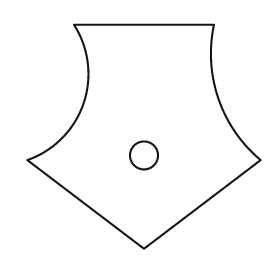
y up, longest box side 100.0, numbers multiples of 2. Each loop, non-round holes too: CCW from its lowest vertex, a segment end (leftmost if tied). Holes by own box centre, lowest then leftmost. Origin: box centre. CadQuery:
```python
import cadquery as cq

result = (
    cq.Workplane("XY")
    .moveTo(0.0, -48.0)
    .lineTo(50.0, -10.0)
    .threePointArc((32.0, 16.0), (30.0, 48.0))
    .lineTo(-30.0, 48.0)
    .threePointArc((-26.0, 14.0), (-50.0, -10.0))
    .close()
    .moveTo(0.0, -8.0)
    .circle(6.0)
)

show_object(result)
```